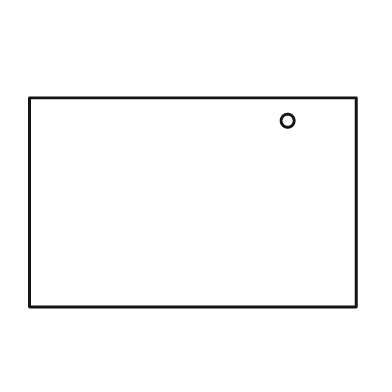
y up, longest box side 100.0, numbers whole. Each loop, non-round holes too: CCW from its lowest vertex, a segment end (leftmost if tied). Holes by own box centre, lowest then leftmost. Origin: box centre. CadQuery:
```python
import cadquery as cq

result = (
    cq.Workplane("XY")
    .moveTo(-50.0, -32.0)
    .lineTo(50.0, -32.0)
    .lineTo(50.0, 32.0)
    .lineTo(-50.0, 32.0)
    .close()
    .moveTo(29.0, 25.0)
    .circle(2.0)
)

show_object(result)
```